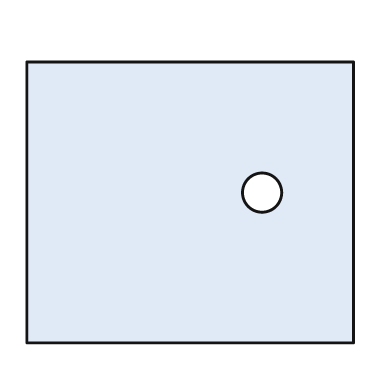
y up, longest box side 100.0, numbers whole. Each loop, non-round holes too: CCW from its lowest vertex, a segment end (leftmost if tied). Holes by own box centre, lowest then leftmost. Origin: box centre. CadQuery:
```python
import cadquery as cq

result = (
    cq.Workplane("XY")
    .moveTo(-50.0, -43.0)
    .lineTo(50.0, -43.0)
    .lineTo(50.0, 43.0)
    .lineTo(-50.0, 43.0)
    .close()
    .moveTo(22.0, 3.0)
    .circle(6.0)
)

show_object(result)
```